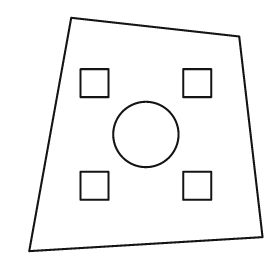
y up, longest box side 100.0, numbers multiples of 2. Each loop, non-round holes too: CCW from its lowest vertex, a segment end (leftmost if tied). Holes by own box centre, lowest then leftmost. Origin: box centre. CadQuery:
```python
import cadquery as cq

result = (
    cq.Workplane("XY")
    .moveTo(-50.0, -50.0)
    .lineTo(50.0, -44.0)
    .lineTo(40.0, 42.0)
    .lineTo(-32.0, 50.0)
    .close()
    .moveTo(-28.0, -28.0)
    .lineTo(-16.0, -28.0)
    .lineTo(-16.0, -16.0)
    .lineTo(-28.0, -16.0)
    .close()
    .moveTo(16.0, -28.0)
    .lineTo(28.0, -28.0)
    .lineTo(28.0, -16.0)
    .lineTo(16.0, -16.0)
    .close()
    .moveTo(0.0, 0.0)
    .circle(14.0)
    .moveTo(-28.0, 16.0)
    .lineTo(-16.0, 16.0)
    .lineTo(-16.0, 28.0)
    .lineTo(-28.0, 28.0)
    .close()
    .moveTo(16.0, 16.0)
    .lineTo(28.0, 16.0)
    .lineTo(28.0, 28.0)
    .lineTo(16.0, 28.0)
    .close()
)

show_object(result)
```